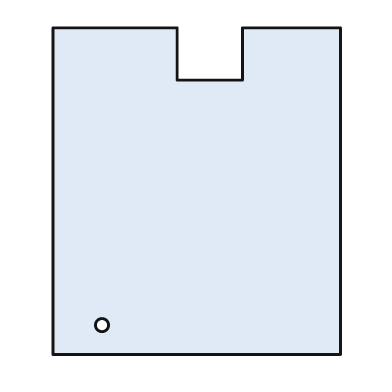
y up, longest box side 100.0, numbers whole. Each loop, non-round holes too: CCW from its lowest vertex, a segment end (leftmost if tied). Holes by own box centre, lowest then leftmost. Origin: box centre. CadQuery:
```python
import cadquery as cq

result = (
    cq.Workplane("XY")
    .moveTo(-44.0, -50.0)
    .lineTo(44.0, -50.0)
    .lineTo(44.0, 50.0)
    .lineTo(14.0, 50.0)
    .lineTo(14.0, 34.0)
    .lineTo(-6.0, 34.0)
    .lineTo(-6.0, 50.0)
    .lineTo(-44.0, 50.0)
    .close()
    .moveTo(-29.0, -41.0)
    .circle(2.0)
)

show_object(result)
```